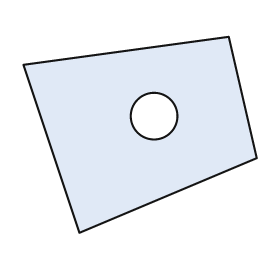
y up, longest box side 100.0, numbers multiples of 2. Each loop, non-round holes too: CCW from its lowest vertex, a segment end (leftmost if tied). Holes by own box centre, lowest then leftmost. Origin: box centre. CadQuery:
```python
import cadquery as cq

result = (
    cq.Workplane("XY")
    .moveTo(-26.0, -42.0)
    .lineTo(50.0, -10.0)
    .lineTo(38.0, 42.0)
    .lineTo(-50.0, 30.0)
    .close()
    .moveTo(6.0, 8.0)
    .circle(10.0)
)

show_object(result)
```